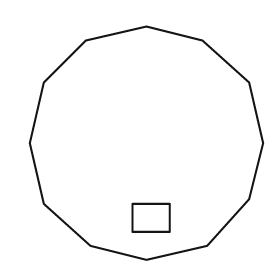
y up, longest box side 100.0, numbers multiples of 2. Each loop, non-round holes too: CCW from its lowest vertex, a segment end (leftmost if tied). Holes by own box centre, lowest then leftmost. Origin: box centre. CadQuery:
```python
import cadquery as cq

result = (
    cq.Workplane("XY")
    .moveTo(0.0, -50.0)
    .lineTo(26.0, -44.0)
    .lineTo(44.0, -24.0)
    .lineTo(50.0, 0.0)
    .lineTo(44.0, 26.0)
    .lineTo(24.0, 44.0)
    .lineTo(0.0, 50.0)
    .lineTo(-26.0, 44.0)
    .lineTo(-44.0, 26.0)
    .lineTo(-50.0, 0.0)
    .lineTo(-44.0, -26.0)
    .lineTo(-24.0, -44.0)
    .close()
    .moveTo(-6.0, -38.0)
    .lineTo(10.0, -38.0)
    .lineTo(10.0, -26.0)
    .lineTo(-6.0, -26.0)
    .close()
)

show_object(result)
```